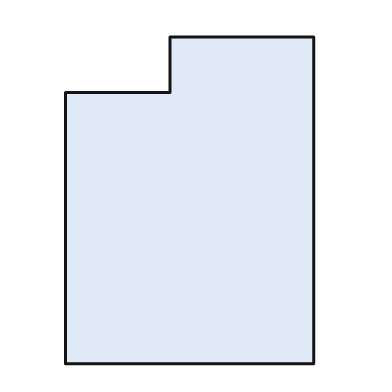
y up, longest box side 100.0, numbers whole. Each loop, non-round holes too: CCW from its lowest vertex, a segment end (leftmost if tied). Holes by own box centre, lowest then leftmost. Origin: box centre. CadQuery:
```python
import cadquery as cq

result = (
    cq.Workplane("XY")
    .moveTo(-38.0, -50.0)
    .lineTo(38.0, -50.0)
    .lineTo(38.0, 50.0)
    .lineTo(-6.0, 50.0)
    .lineTo(-6.0, 33.0)
    .lineTo(-38.0, 33.0)
    .close()
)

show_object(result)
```